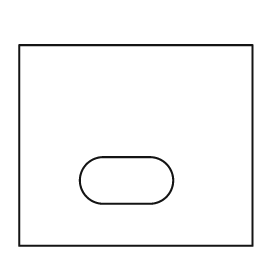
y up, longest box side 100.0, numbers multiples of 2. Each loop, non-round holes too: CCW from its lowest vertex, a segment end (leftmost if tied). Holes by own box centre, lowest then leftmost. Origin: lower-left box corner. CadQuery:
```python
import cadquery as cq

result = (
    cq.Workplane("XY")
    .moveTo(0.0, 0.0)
    .lineTo(100.0, 0.0)
    .lineTo(100.0, 86.0)
    .lineTo(0.0, 86.0)
    .close()
    .moveTo(36.0, 18.0)
    .lineTo(56.0, 18.0)
    .threePointArc((66.0, 28.0), (56.0, 38.0))
    .lineTo(36.0, 38.0)
    .threePointArc((26.0, 28.0), (36.0, 18.0))
    .close()
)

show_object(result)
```